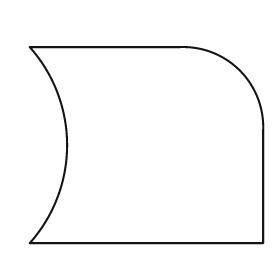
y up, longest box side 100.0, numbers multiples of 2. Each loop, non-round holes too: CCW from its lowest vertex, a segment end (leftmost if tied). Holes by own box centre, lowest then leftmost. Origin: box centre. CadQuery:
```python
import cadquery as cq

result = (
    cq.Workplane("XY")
    .moveTo(-50.0, -42.0)
    .lineTo(50.0, -42.0)
    .lineTo(50.0, 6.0)
    .threePointArc((40.0, 32.0), (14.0, 42.0))
    .lineTo(-50.0, 42.0)
    .threePointArc((-34.0, 0.0), (-50.0, -42.0))
    .close()
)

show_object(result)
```